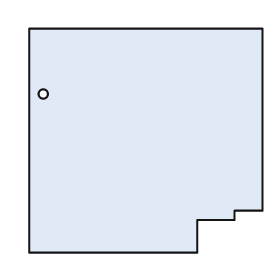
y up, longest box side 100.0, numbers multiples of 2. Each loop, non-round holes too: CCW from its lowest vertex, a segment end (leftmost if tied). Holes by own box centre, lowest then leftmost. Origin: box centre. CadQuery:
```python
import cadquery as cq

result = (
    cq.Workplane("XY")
    .moveTo(-50.0, -48.0)
    .lineTo(22.0, -48.0)
    .lineTo(22.0, -34.0)
    .lineTo(38.0, -34.0)
    .lineTo(38.0, -30.0)
    .lineTo(50.0, -30.0)
    .lineTo(50.0, 48.0)
    .lineTo(-50.0, 48.0)
    .close()
    .moveTo(-44.0, 20.0)
    .circle(2.0)
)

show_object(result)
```